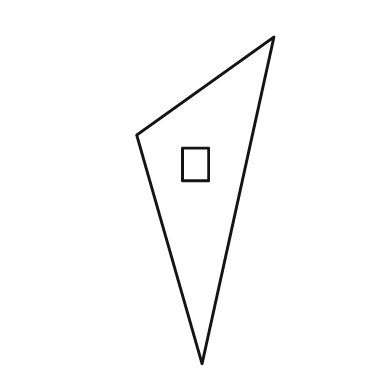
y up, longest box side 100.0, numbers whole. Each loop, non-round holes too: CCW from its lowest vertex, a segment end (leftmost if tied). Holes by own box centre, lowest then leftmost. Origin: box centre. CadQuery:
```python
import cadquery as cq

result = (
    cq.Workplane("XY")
    .moveTo(-1.0, -50.0)
    .lineTo(21.0, 50.0)
    .lineTo(-21.0, 20.0)
    .close()
    .moveTo(-7.0, 6.0)
    .lineTo(1.0, 6.0)
    .lineTo(1.0, 16.0)
    .lineTo(-7.0, 16.0)
    .close()
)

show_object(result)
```